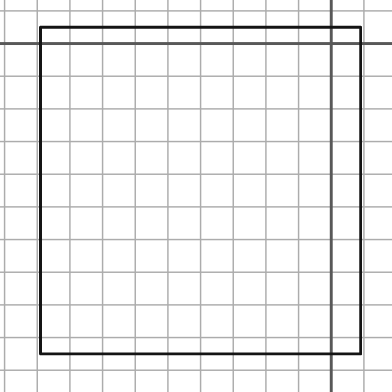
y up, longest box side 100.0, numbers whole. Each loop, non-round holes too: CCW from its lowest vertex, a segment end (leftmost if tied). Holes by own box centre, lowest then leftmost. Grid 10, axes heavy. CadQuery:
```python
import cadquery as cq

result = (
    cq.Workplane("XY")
    .moveTo(-89.0, -95.0)
    .lineTo(9.0, -95.0)
    .lineTo(9.0, 5.0)
    .lineTo(-89.0, 5.0)
    .close()
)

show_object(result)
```